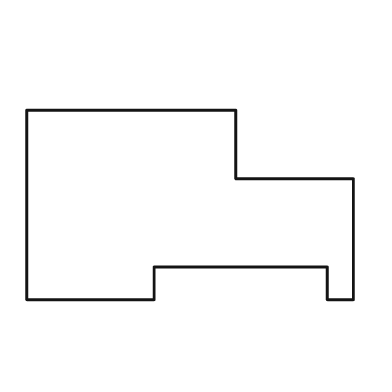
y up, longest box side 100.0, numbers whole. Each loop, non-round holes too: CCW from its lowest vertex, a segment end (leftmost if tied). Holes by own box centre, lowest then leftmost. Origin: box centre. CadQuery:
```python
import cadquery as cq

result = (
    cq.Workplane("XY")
    .moveTo(-50.0, -29.0)
    .lineTo(-11.0, -29.0)
    .lineTo(-11.0, -19.0)
    .lineTo(42.0, -19.0)
    .lineTo(42.0, -29.0)
    .lineTo(50.0, -29.0)
    .lineTo(50.0, 8.0)
    .lineTo(14.0, 8.0)
    .lineTo(14.0, 29.0)
    .lineTo(-50.0, 29.0)
    .close()
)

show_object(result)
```